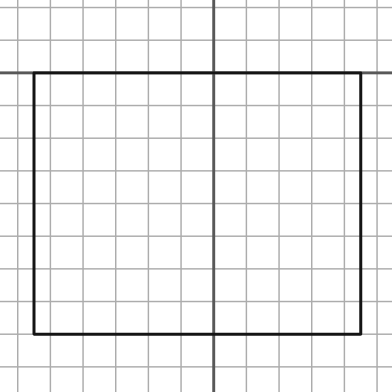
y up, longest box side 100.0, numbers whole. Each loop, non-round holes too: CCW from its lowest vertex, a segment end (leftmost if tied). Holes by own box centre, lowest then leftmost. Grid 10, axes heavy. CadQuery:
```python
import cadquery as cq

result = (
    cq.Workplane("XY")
    .moveTo(-55.0, -80.0)
    .lineTo(45.0, -80.0)
    .lineTo(45.0, 0.0)
    .lineTo(-55.0, 0.0)
    .close()
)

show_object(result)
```